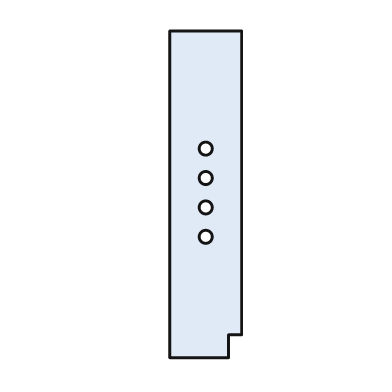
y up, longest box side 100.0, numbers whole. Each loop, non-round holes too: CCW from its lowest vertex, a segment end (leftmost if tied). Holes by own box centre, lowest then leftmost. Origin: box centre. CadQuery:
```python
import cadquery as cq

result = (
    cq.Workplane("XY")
    .moveTo(-11.0, -50.0)
    .lineTo(7.0, -50.0)
    .lineTo(7.0, -43.0)
    .lineTo(11.0, -43.0)
    .lineTo(11.0, 50.0)
    .lineTo(-11.0, 50.0)
    .close()
    .moveTo(0.0, -13.0)
    .circle(2.0)
    .moveTo(0.0, -4.0)
    .circle(2.0)
    .moveTo(0.0, 5.0)
    .circle(2.0)
    .moveTo(0.0, 14.0)
    .circle(2.0)
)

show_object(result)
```